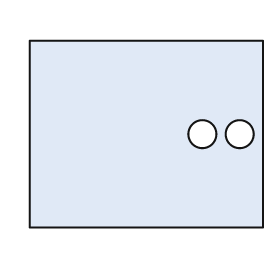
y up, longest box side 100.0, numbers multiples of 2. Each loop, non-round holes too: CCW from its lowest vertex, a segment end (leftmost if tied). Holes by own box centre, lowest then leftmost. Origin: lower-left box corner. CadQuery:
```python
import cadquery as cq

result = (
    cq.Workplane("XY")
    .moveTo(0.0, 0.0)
    .lineTo(100.0, 0.0)
    .lineTo(100.0, 80.0)
    .lineTo(0.0, 80.0)
    .close()
    .moveTo(74.0, 40.0)
    .circle(6.0)
    .moveTo(90.0, 40.0)
    .circle(6.0)
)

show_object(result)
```